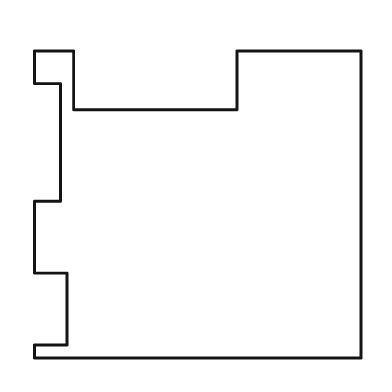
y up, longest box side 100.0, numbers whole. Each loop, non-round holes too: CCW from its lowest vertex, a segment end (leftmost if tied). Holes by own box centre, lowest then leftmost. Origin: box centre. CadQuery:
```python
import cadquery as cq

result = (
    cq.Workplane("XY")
    .moveTo(-50.0, -47.0)
    .lineTo(50.0, -47.0)
    .lineTo(50.0, 47.0)
    .lineTo(12.0, 47.0)
    .lineTo(12.0, 29.0)
    .lineTo(-38.0, 29.0)
    .lineTo(-38.0, 47.0)
    .lineTo(-50.0, 47.0)
    .lineTo(-50.0, 37.0)
    .lineTo(-42.0, 37.0)
    .lineTo(-42.0, 1.0)
    .lineTo(-50.0, 1.0)
    .lineTo(-50.0, -21.0)
    .lineTo(-40.0, -21.0)
    .lineTo(-40.0, -43.0)
    .lineTo(-50.0, -43.0)
    .close()
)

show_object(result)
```